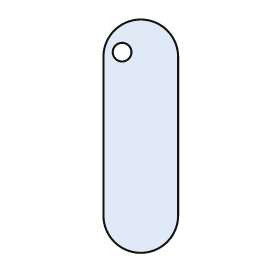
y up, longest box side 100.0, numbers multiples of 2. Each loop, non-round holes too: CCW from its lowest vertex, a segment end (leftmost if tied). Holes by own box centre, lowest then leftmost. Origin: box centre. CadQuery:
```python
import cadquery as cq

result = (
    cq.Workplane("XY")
    .moveTo(-16.0, -34.0)
    .threePointArc((0.0, -50.0), (16.0, -34.0))
    .lineTo(16.0, 34.0)
    .threePointArc((0.0, 50.0), (-16.0, 34.0))
    .close()
    .moveTo(-8.0, 36.0)
    .circle(4.0)
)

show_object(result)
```